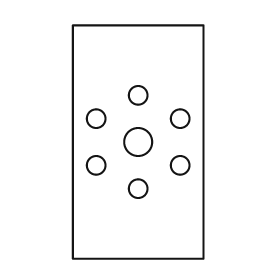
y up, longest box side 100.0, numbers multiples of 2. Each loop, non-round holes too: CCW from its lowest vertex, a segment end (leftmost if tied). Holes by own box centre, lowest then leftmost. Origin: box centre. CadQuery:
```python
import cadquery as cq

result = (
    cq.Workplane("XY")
    .moveTo(-28.0, -50.0)
    .lineTo(28.0, -50.0)
    .lineTo(28.0, 50.0)
    .lineTo(-28.0, 50.0)
    .close()
    .moveTo(0.0, -20.0)
    .circle(4.0)
    .moveTo(-18.0, -10.0)
    .circle(4.0)
    .moveTo(18.0, -10.0)
    .circle(4.0)
    .moveTo(0.0, 0.0)
    .circle(6.0)
    .moveTo(-18.0, 10.0)
    .circle(4.0)
    .moveTo(18.0, 10.0)
    .circle(4.0)
    .moveTo(0.0, 20.0)
    .circle(4.0)
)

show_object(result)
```